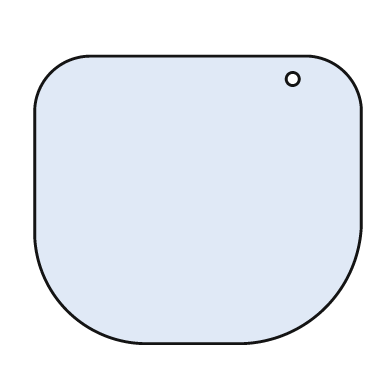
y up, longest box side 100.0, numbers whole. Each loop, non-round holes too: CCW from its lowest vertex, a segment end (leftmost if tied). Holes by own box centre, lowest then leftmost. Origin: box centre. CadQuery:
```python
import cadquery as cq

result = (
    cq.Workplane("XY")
    .moveTo(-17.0, -44.0)
    .lineTo(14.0, -44.0)
    .threePointArc((39.0, -33.0), (50.0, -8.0))
    .lineTo(50.0, 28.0)
    .threePointArc((45.0, 39.0), (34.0, 44.0))
    .lineTo(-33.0, 44.0)
    .threePointArc((-45.0, 39.0), (-50.0, 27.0))
    .lineTo(-50.0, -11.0)
    .threePointArc((-40.0, -34.0), (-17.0, -44.0))
    .close()
    .moveTo(29.0, 37.0)
    .circle(2.0)
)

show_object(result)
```